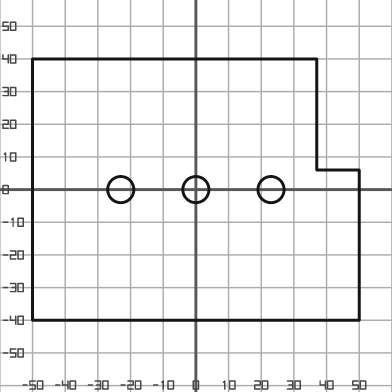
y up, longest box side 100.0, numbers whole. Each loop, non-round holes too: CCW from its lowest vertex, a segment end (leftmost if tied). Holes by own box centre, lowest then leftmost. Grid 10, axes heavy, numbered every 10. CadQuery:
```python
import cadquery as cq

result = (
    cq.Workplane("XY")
    .moveTo(-50.0, -40.0)
    .lineTo(50.0, -40.0)
    .lineTo(50.0, 6.0)
    .lineTo(37.0, 6.0)
    .lineTo(37.0, 40.0)
    .lineTo(-50.0, 40.0)
    .close()
    .moveTo(-23.0, 0.0)
    .circle(4.0)
    .moveTo(0.0, 0.0)
    .circle(4.0)
    .moveTo(23.0, 0.0)
    .circle(4.0)
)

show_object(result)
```